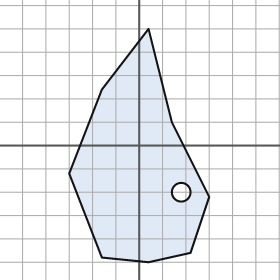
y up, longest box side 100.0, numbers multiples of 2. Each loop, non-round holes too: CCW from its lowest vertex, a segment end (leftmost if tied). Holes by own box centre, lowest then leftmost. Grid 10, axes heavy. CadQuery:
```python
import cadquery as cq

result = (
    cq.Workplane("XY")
    .moveTo(4.0, -50.0)
    .lineTo(22.0, -46.0)
    .lineTo(30.0, -22.0)
    .lineTo(14.0, 10.0)
    .lineTo(4.0, 50.0)
    .lineTo(-16.0, 24.0)
    .lineTo(-30.0, -12.0)
    .lineTo(-16.0, -48.0)
    .close()
    .moveTo(18.0, -20.0)
    .circle(4.0)
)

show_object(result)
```